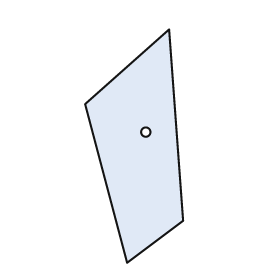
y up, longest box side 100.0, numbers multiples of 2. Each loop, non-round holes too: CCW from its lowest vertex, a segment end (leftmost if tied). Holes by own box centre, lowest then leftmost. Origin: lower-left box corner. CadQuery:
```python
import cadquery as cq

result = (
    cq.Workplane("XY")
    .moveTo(18.0, 0.0)
    .lineTo(42.0, 18.0)
    .lineTo(36.0, 100.0)
    .lineTo(0.0, 68.0)
    .close()
    .moveTo(26.0, 56.0)
    .circle(2.0)
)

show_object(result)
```